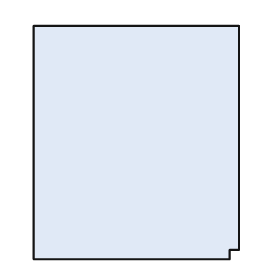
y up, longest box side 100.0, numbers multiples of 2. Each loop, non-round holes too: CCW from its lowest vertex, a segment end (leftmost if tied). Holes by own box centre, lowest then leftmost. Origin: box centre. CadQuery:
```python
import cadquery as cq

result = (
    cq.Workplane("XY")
    .moveTo(-44.0, -50.0)
    .lineTo(40.0, -50.0)
    .lineTo(40.0, -46.0)
    .lineTo(44.0, -46.0)
    .lineTo(44.0, 50.0)
    .lineTo(-44.0, 50.0)
    .close()
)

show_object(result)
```